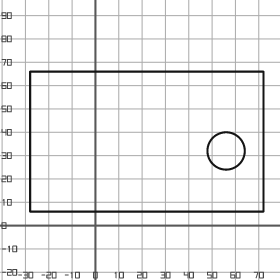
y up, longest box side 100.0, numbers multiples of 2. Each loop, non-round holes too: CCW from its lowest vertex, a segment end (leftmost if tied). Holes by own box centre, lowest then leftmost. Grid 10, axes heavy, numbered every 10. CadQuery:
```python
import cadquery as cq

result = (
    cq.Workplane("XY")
    .moveTo(-28.0, 6.0)
    .lineTo(72.0, 6.0)
    .lineTo(72.0, 66.0)
    .lineTo(-28.0, 66.0)
    .close()
    .moveTo(56.0, 32.0)
    .circle(8.0)
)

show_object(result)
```